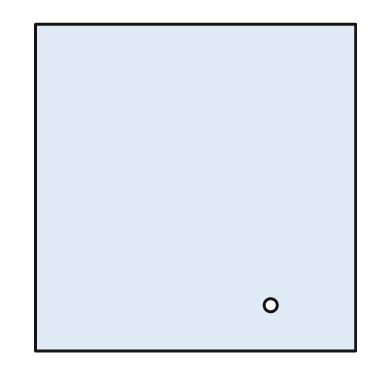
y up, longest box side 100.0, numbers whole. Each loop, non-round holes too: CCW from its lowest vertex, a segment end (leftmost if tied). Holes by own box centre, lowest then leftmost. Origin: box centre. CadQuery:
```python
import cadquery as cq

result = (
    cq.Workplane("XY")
    .moveTo(-49.0, -50.0)
    .lineTo(49.0, -50.0)
    .lineTo(49.0, 50.0)
    .lineTo(-49.0, 50.0)
    .close()
    .moveTo(23.0, -36.0)
    .circle(2.0)
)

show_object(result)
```